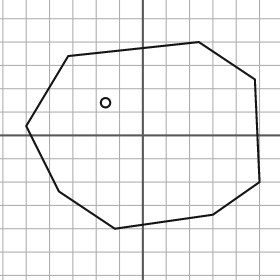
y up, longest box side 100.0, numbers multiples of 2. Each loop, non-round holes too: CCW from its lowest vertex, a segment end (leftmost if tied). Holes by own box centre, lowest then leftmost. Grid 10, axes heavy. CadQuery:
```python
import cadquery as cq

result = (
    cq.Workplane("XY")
    .moveTo(-12.0, -40.0)
    .lineTo(30.0, -34.0)
    .lineTo(50.0, -20.0)
    .lineTo(48.0, 24.0)
    .lineTo(24.0, 40.0)
    .lineTo(-32.0, 34.0)
    .lineTo(-50.0, 4.0)
    .lineTo(-36.0, -24.0)
    .close()
    .moveTo(-16.0, 14.0)
    .circle(2.0)
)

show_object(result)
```